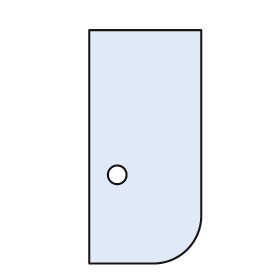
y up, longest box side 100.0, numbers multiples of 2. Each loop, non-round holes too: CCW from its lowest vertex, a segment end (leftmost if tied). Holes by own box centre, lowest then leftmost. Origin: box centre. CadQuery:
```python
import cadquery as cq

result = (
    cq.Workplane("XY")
    .moveTo(-24.0, -50.0)
    .lineTo(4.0, -50.0)
    .threePointArc((18.0, -44.0), (24.0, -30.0))
    .lineTo(24.0, 50.0)
    .lineTo(-24.0, 50.0)
    .close()
    .moveTo(-12.0, -12.0)
    .circle(4.0)
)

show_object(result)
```